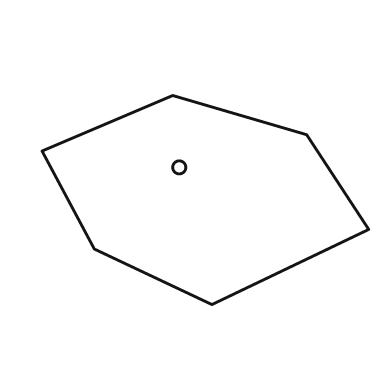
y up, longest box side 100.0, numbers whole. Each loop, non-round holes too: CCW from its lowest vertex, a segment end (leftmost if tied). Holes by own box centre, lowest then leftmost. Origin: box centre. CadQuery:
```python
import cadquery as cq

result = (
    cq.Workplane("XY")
    .moveTo(2.0, -32.0)
    .lineTo(50.0, -9.0)
    .lineTo(31.0, 20.0)
    .lineTo(-10.0, 32.0)
    .lineTo(-50.0, 15.0)
    .lineTo(-34.0, -15.0)
    .close()
    .moveTo(-8.0, 10.0)
    .circle(2.0)
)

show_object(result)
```